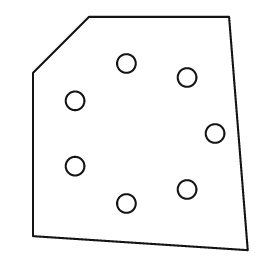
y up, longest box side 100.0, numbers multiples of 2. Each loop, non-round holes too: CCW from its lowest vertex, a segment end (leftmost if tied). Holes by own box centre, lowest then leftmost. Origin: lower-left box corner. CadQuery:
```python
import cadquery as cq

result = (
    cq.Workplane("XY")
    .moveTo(92.0, 0.0)
    .lineTo(84.0, 100.0)
    .lineTo(24.0, 100.0)
    .lineTo(0.0, 76.0)
    .lineTo(0.0, 6.0)
    .close()
    .moveTo(40.0, 20.0)
    .circle(4.0)
    .moveTo(66.0, 26.0)
    .circle(4.0)
    .moveTo(18.0, 36.0)
    .circle(4.0)
    .moveTo(78.0, 50.0)
    .circle(4.0)
    .moveTo(18.0, 64.0)
    .circle(4.0)
    .moveTo(66.0, 74.0)
    .circle(4.0)
    .moveTo(40.0, 80.0)
    .circle(4.0)
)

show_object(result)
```